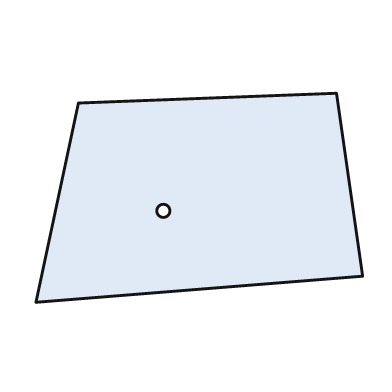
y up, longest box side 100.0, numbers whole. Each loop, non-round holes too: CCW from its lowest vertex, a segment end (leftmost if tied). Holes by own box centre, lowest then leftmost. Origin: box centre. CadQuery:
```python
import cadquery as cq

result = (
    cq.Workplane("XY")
    .moveTo(-50.0, -32.0)
    .lineTo(50.0, -24.0)
    .lineTo(42.0, 32.0)
    .lineTo(-37.0, 29.0)
    .close()
    .moveTo(-11.0, -4.0)
    .circle(2.0)
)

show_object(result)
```